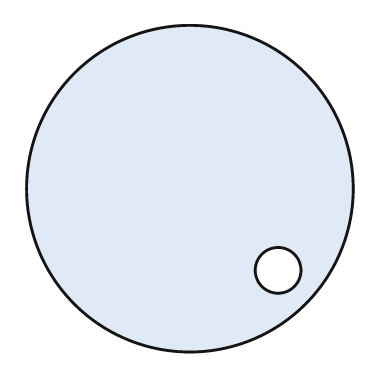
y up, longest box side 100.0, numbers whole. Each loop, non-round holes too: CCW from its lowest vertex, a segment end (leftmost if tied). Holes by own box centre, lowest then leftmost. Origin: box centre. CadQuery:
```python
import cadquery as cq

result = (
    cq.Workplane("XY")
    .moveTo(0.0, 0.0)
    .circle(50.0)
    .moveTo(27.0, -25.0)
    .circle(7.0)
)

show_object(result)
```